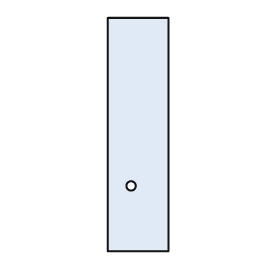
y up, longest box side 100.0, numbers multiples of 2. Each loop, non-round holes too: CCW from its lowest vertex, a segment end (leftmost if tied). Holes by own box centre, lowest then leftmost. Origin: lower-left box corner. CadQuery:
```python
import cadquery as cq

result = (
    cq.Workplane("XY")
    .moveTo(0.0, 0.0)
    .lineTo(26.0, 0.0)
    .lineTo(26.0, 100.0)
    .lineTo(0.0, 100.0)
    .close()
    .moveTo(10.0, 28.0)
    .circle(2.0)
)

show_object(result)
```